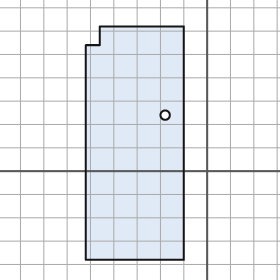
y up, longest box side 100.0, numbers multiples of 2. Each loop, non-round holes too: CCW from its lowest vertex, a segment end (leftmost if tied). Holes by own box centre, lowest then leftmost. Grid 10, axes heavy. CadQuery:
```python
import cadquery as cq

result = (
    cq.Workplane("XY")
    .moveTo(-52.0, -38.0)
    .lineTo(-10.0, -38.0)
    .lineTo(-10.0, 62.0)
    .lineTo(-46.0, 62.0)
    .lineTo(-46.0, 54.0)
    .lineTo(-52.0, 54.0)
    .close()
    .moveTo(-18.0, 24.0)
    .circle(2.0)
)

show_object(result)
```